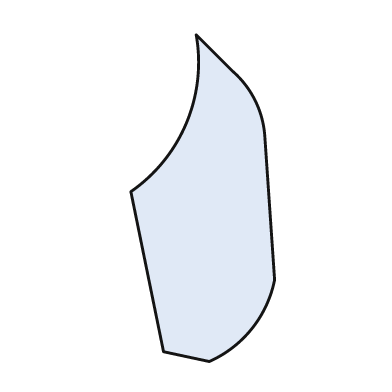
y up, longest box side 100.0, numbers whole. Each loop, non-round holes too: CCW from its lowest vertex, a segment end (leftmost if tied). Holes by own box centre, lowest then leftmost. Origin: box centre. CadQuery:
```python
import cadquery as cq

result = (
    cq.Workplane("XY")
    .moveTo(2.0, -50.0)
    .threePointArc((15.0, -40.0), (22.0, -25.0))
    .lineTo(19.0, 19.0)
    .threePointArc((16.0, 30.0), (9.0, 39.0))
    .lineTo(-2.0, 50.0)
    .threePointArc((-5.0, 23.0), (-22.0, 2.0))
    .lineTo(-12.0, -47.0)
    .close()
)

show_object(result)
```